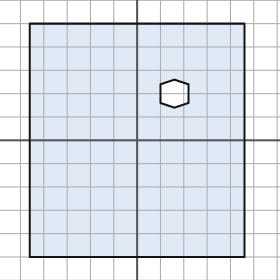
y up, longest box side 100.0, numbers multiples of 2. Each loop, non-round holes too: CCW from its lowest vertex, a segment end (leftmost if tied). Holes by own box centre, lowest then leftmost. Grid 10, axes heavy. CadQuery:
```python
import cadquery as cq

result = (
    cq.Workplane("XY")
    .moveTo(-46.0, -50.0)
    .lineTo(46.0, -50.0)
    .lineTo(46.0, 50.0)
    .lineTo(-46.0, 50.0)
    .close()
    .moveTo(16.0, 14.0)
    .lineTo(22.0, 16.0)
    .lineTo(22.0, 24.0)
    .lineTo(16.0, 26.0)
    .lineTo(10.0, 24.0)
    .lineTo(10.0, 16.0)
    .close()
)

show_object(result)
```